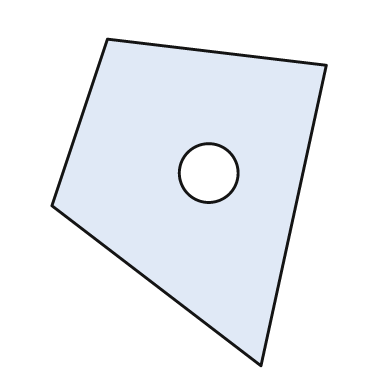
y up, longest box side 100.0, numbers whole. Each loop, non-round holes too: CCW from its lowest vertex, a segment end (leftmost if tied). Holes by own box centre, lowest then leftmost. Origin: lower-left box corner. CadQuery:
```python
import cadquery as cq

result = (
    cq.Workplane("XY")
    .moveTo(64.0, 0.0)
    .lineTo(84.0, 92.0)
    .lineTo(17.0, 100.0)
    .lineTo(0.0, 49.0)
    .close()
    .moveTo(48.0, 59.0)
    .circle(9.0)
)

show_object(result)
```